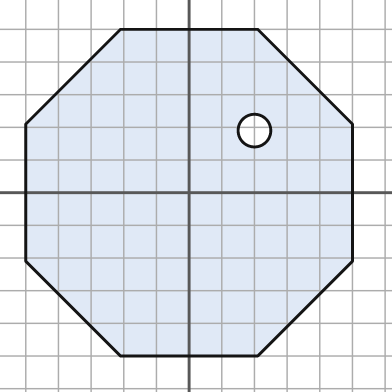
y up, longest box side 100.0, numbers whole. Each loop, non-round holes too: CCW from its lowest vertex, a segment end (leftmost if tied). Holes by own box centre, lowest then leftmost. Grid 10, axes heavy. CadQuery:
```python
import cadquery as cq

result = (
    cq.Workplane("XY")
    .moveTo(-21.0, -50.0)
    .lineTo(21.0, -50.0)
    .lineTo(50.0, -21.0)
    .lineTo(50.0, 21.0)
    .lineTo(21.0, 50.0)
    .lineTo(-21.0, 50.0)
    .lineTo(-50.0, 21.0)
    .lineTo(-50.0, -21.0)
    .close()
    .moveTo(20.0, 19.0)
    .circle(5.0)
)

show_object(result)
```